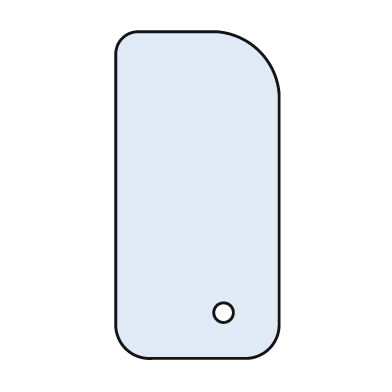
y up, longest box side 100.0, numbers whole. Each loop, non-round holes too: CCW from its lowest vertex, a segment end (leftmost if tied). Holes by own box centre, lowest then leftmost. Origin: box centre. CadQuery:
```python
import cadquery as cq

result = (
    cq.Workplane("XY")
    .moveTo(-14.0, -50.0)
    .lineTo(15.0, -50.0)
    .threePointArc((22.0, -47.0), (25.0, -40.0))
    .lineTo(25.0, 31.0)
    .threePointArc((19.0, 44.0), (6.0, 50.0))
    .lineTo(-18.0, 50.0)
    .threePointArc((-23.0, 48.0), (-25.0, 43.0))
    .lineTo(-25.0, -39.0)
    .threePointArc((-22.0, -47.0), (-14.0, -50.0))
    .close()
    .moveTo(8.0, -36.0)
    .circle(3.0)
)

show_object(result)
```